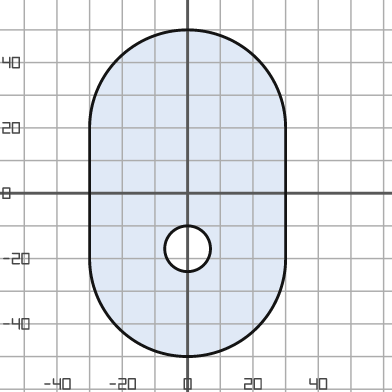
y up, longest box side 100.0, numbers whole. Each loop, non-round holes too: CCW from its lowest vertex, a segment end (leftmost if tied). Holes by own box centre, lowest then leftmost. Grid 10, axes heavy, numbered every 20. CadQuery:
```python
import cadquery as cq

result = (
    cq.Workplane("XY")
    .moveTo(-30.0, -20.0)
    .threePointArc((0.0, -50.0), (30.0, -20.0))
    .lineTo(30.0, 20.0)
    .threePointArc((0.0, 50.0), (-30.0, 20.0))
    .close()
    .moveTo(0.0, -17.0)
    .circle(7.0)
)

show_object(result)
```